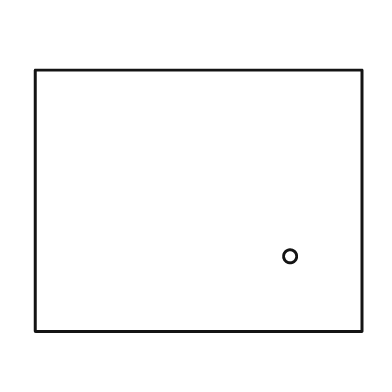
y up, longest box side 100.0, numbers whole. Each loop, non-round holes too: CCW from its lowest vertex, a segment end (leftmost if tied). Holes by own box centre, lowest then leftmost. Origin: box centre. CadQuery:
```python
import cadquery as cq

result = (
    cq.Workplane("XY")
    .moveTo(-50.0, -40.0)
    .lineTo(50.0, -40.0)
    .lineTo(50.0, 40.0)
    .lineTo(-50.0, 40.0)
    .close()
    .moveTo(28.0, -17.0)
    .circle(2.0)
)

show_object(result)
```